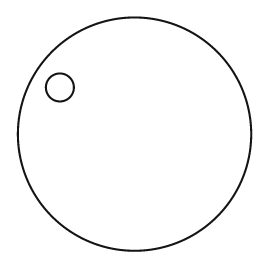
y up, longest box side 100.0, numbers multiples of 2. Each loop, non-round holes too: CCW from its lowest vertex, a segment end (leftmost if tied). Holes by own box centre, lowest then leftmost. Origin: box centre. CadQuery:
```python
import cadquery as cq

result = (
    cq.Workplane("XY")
    .moveTo(0.0, 0.0)
    .circle(50.0)
    .moveTo(-32.0, 20.0)
    .circle(6.0)
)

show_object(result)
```